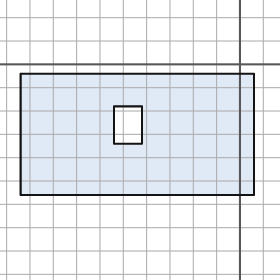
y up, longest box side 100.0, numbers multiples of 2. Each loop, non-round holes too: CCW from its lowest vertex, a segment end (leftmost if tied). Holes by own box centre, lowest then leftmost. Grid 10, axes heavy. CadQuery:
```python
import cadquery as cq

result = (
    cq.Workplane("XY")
    .moveTo(-94.0, -56.0)
    .lineTo(6.0, -56.0)
    .lineTo(6.0, -4.0)
    .lineTo(-94.0, -4.0)
    .close()
    .moveTo(-54.0, -34.0)
    .lineTo(-42.0, -34.0)
    .lineTo(-42.0, -18.0)
    .lineTo(-54.0, -18.0)
    .close()
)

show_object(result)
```